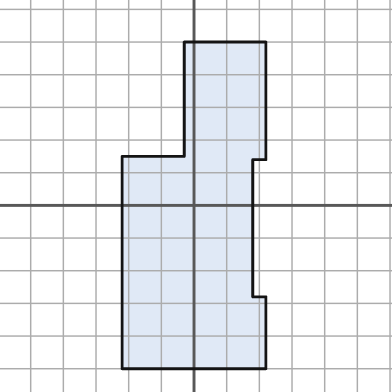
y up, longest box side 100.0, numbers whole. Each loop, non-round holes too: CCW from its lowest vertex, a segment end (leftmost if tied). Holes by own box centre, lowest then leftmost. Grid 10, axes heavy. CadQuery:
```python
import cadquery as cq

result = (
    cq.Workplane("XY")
    .moveTo(-22.0, -50.0)
    .lineTo(22.0, -50.0)
    .lineTo(22.0, -28.0)
    .lineTo(18.0, -28.0)
    .lineTo(18.0, 14.0)
    .lineTo(22.0, 14.0)
    .lineTo(22.0, 50.0)
    .lineTo(-3.0, 50.0)
    .lineTo(-3.0, 15.0)
    .lineTo(-22.0, 15.0)
    .close()
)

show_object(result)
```